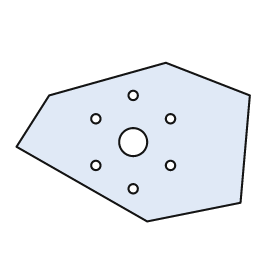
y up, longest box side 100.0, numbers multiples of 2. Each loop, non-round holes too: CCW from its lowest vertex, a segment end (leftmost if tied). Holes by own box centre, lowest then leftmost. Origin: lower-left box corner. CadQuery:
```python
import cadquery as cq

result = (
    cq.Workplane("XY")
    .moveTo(56.0, 0.0)
    .lineTo(96.0, 8.0)
    .lineTo(100.0, 54.0)
    .lineTo(64.0, 68.0)
    .lineTo(14.0, 54.0)
    .lineTo(0.0, 32.0)
    .close()
    .moveTo(50.0, 14.0)
    .circle(2.0)
    .moveTo(34.0, 24.0)
    .circle(2.0)
    .moveTo(66.0, 24.0)
    .circle(2.0)
    .moveTo(50.0, 34.0)
    .circle(6.0)
    .moveTo(34.0, 44.0)
    .circle(2.0)
    .moveTo(66.0, 44.0)
    .circle(2.0)
    .moveTo(50.0, 54.0)
    .circle(2.0)
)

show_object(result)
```